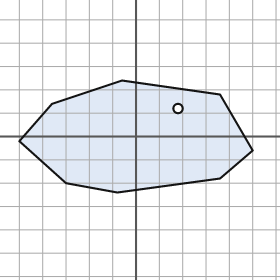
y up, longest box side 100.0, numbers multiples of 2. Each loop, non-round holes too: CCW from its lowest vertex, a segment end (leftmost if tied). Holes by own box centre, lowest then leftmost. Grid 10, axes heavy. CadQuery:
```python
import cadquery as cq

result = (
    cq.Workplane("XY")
    .moveTo(-8.0, -24.0)
    .lineTo(36.0, -18.0)
    .lineTo(50.0, -6.0)
    .lineTo(36.0, 18.0)
    .lineTo(-6.0, 24.0)
    .lineTo(-36.0, 14.0)
    .lineTo(-50.0, -2.0)
    .lineTo(-30.0, -20.0)
    .close()
    .moveTo(18.0, 12.0)
    .circle(2.0)
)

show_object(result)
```